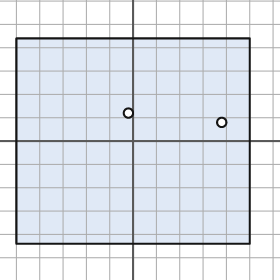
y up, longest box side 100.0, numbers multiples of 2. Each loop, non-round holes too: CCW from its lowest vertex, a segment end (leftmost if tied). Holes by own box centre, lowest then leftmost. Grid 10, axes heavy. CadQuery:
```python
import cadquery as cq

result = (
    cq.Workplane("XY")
    .moveTo(-50.0, -44.0)
    .lineTo(50.0, -44.0)
    .lineTo(50.0, 44.0)
    .lineTo(-50.0, 44.0)
    .close()
    .moveTo(38.0, 8.0)
    .circle(2.0)
    .moveTo(-2.0, 12.0)
    .circle(2.0)
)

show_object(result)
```